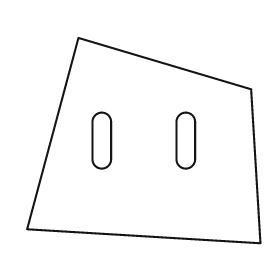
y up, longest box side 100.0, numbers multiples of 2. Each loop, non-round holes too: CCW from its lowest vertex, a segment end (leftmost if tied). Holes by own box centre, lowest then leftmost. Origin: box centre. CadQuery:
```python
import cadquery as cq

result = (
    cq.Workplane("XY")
    .moveTo(50.0, -44.0)
    .lineTo(46.0, 22.0)
    .lineTo(-28.0, 44.0)
    .lineTo(-50.0, -38.0)
    .close()
    .moveTo(-22.0, -8.0)
    .threePointArc((-18.0, -12.0), (-14.0, -8.0))
    .lineTo(-14.0, 8.0)
    .threePointArc((-18.0, 12.0), (-22.0, 8.0))
    .close()
    .moveTo(14.0, -8.0)
    .threePointArc((18.0, -12.0), (22.0, -8.0))
    .lineTo(22.0, 8.0)
    .threePointArc((18.0, 12.0), (14.0, 8.0))
    .close()
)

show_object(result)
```